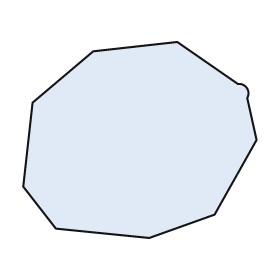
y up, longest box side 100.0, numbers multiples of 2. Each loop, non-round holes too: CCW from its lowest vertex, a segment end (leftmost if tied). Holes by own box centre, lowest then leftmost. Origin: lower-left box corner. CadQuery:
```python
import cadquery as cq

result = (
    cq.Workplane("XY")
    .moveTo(54.0, 0.0)
    .lineTo(82.0, 10.0)
    .lineTo(100.0, 42.0)
    .lineTo(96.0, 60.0)
    .threePointArc((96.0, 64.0), (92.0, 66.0))
    .lineTo(66.0, 84.0)
    .lineTo(30.0, 80.0)
    .lineTo(4.0, 58.0)
    .lineTo(0.0, 22.0)
    .lineTo(14.0, 4.0)
    .close()
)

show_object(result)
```